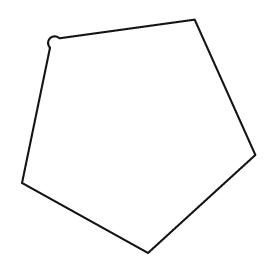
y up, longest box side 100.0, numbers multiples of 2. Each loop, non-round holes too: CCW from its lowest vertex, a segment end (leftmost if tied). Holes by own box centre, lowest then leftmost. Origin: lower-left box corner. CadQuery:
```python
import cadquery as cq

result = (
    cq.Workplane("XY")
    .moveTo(54.0, 0.0)
    .lineTo(100.0, 42.0)
    .lineTo(74.0, 100.0)
    .lineTo(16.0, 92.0)
    .threePointArc((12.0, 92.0), (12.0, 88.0))
    .lineTo(0.0, 30.0)
    .close()
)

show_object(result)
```